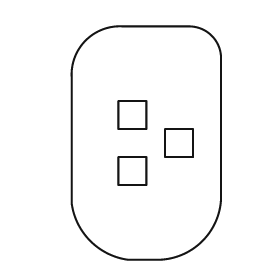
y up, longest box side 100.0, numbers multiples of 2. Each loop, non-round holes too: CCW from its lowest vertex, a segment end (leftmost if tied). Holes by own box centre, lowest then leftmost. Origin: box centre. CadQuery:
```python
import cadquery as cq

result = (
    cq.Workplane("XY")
    .moveTo(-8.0, -50.0)
    .lineTo(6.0, -50.0)
    .threePointArc((24.0, -42.0), (32.0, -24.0))
    .lineTo(32.0, 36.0)
    .threePointArc((28.0, 46.0), (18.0, 50.0))
    .lineTo(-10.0, 50.0)
    .threePointArc((-26.0, 44.0), (-32.0, 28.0))
    .lineTo(-32.0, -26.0)
    .threePointArc((-24.0, -42.0), (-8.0, -50.0))
    .close()
    .moveTo(-12.0, -18.0)
    .lineTo(0.0, -18.0)
    .lineTo(0.0, -6.0)
    .lineTo(-12.0, -6.0)
    .close()
    .moveTo(8.0, -6.0)
    .lineTo(20.0, -6.0)
    .lineTo(20.0, 6.0)
    .lineTo(8.0, 6.0)
    .close()
    .moveTo(-12.0, 6.0)
    .lineTo(0.0, 6.0)
    .lineTo(0.0, 18.0)
    .lineTo(-12.0, 18.0)
    .close()
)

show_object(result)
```